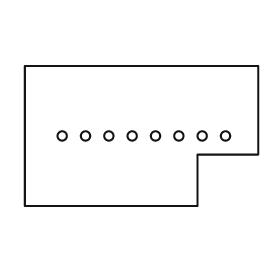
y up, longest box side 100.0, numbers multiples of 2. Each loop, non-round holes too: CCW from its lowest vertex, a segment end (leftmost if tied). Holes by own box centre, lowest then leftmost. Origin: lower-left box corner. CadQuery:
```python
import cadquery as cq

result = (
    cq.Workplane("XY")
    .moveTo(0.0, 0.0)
    .lineTo(74.0, 0.0)
    .lineTo(74.0, 22.0)
    .lineTo(100.0, 22.0)
    .lineTo(100.0, 60.0)
    .lineTo(0.0, 60.0)
    .close()
    .moveTo(16.0, 30.0)
    .circle(2.0)
    .moveTo(26.0, 30.0)
    .circle(2.0)
    .moveTo(36.0, 30.0)
    .circle(2.0)
    .moveTo(46.0, 30.0)
    .circle(2.0)
    .moveTo(56.0, 30.0)
    .circle(2.0)
    .moveTo(66.0, 30.0)
    .circle(2.0)
    .moveTo(76.0, 30.0)
    .circle(2.0)
    .moveTo(86.0, 30.0)
    .circle(2.0)
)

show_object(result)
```